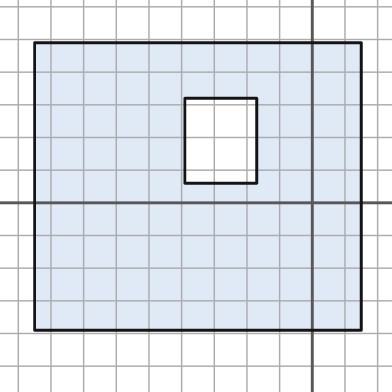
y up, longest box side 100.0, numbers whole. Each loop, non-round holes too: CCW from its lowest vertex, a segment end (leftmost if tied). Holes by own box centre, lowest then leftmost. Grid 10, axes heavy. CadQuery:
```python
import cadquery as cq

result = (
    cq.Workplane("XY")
    .moveTo(-85.0, -39.0)
    .lineTo(15.0, -39.0)
    .lineTo(15.0, 49.0)
    .lineTo(-85.0, 49.0)
    .close()
    .moveTo(-39.0, 6.0)
    .lineTo(-17.0, 6.0)
    .lineTo(-17.0, 32.0)
    .lineTo(-39.0, 32.0)
    .close()
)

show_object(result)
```